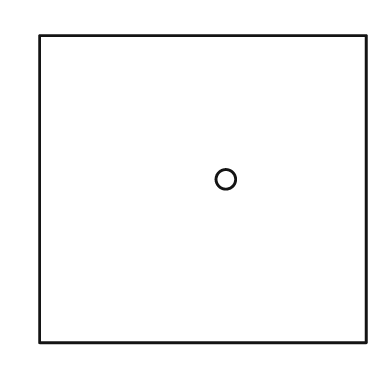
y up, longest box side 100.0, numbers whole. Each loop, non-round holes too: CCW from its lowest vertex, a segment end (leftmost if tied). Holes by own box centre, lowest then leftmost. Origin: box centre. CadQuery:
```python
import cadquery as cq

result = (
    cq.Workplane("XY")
    .moveTo(-50.0, -47.0)
    .lineTo(50.0, -47.0)
    .lineTo(50.0, 47.0)
    .lineTo(-50.0, 47.0)
    .close()
    .moveTo(7.0, 3.0)
    .circle(3.0)
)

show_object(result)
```